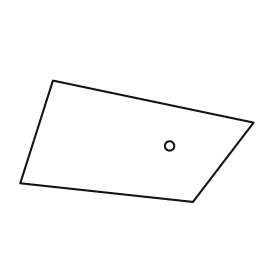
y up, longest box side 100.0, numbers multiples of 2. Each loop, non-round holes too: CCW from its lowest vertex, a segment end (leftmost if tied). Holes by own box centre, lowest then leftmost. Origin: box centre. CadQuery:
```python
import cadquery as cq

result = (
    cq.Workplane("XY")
    .moveTo(24.0, -26.0)
    .lineTo(50.0, 8.0)
    .lineTo(-36.0, 26.0)
    .lineTo(-50.0, -18.0)
    .close()
    .moveTo(14.0, -2.0)
    .circle(2.0)
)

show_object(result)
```